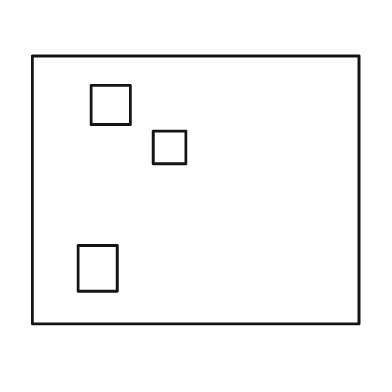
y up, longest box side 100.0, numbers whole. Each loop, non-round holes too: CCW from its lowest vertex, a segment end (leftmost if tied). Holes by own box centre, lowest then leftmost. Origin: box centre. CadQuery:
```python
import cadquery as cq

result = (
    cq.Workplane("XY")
    .moveTo(-50.0, -41.0)
    .lineTo(50.0, -41.0)
    .lineTo(50.0, 41.0)
    .lineTo(-50.0, 41.0)
    .close()
    .moveTo(-36.0, -31.0)
    .lineTo(-24.0, -31.0)
    .lineTo(-24.0, -17.0)
    .lineTo(-36.0, -17.0)
    .close()
    .moveTo(-13.0, 8.0)
    .lineTo(-3.0, 8.0)
    .lineTo(-3.0, 18.0)
    .lineTo(-13.0, 18.0)
    .close()
    .moveTo(-32.0, 20.0)
    .lineTo(-20.0, 20.0)
    .lineTo(-20.0, 32.0)
    .lineTo(-32.0, 32.0)
    .close()
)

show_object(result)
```